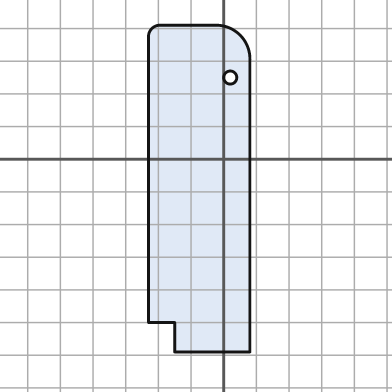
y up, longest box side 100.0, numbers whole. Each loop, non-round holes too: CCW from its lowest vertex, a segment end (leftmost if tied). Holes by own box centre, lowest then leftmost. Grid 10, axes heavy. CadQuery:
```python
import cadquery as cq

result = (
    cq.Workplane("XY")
    .moveTo(-15.0, -59.0)
    .lineTo(8.0, -59.0)
    .lineTo(8.0, 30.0)
    .threePointArc((5.0, 38.0), (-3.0, 41.0))
    .lineTo(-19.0, 41.0)
    .threePointArc((-22.0, 40.0), (-23.0, 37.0))
    .lineTo(-23.0, -50.0)
    .lineTo(-15.0, -50.0)
    .close()
    .moveTo(2.0, 25.0)
    .circle(2.0)
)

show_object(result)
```